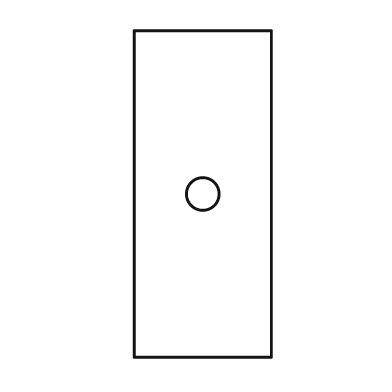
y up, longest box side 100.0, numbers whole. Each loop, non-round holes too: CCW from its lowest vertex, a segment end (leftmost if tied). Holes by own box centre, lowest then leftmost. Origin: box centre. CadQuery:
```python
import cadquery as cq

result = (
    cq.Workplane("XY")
    .moveTo(-21.0, -50.0)
    .lineTo(21.0, -50.0)
    .lineTo(21.0, 50.0)
    .lineTo(-21.0, 50.0)
    .close()
    .moveTo(0.0, 0.0)
    .circle(5.0)
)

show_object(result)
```